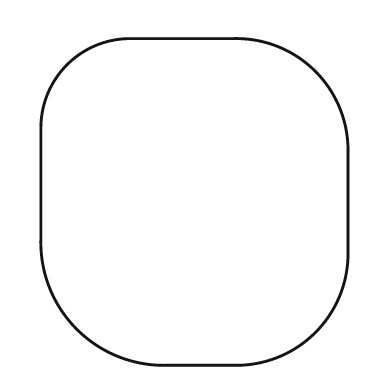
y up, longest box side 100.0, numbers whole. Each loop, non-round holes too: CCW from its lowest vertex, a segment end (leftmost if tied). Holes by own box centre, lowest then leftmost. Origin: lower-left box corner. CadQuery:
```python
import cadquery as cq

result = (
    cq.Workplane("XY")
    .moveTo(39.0, 0.0)
    .lineTo(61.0, 0.0)
    .threePointArc((84.0, 10.0), (94.0, 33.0))
    .lineTo(94.0, 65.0)
    .threePointArc((84.0, 90.0), (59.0, 100.0))
    .lineTo(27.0, 100.0)
    .threePointArc((8.0, 92.0), (0.0, 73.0))
    .lineTo(0.0, 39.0)
    .threePointArc((11.0, 11.0), (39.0, 0.0))
    .close()
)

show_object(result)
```